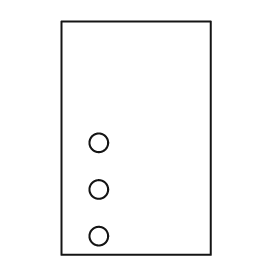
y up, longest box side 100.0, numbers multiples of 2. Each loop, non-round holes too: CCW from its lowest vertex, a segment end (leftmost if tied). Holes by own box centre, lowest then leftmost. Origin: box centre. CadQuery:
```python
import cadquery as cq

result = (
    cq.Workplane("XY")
    .moveTo(-32.0, -50.0)
    .lineTo(32.0, -50.0)
    .lineTo(32.0, 50.0)
    .lineTo(-32.0, 50.0)
    .close()
    .moveTo(-16.0, -42.0)
    .circle(4.0)
    .moveTo(-16.0, -22.0)
    .circle(4.0)
    .moveTo(-16.0, -2.0)
    .circle(4.0)
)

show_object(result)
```